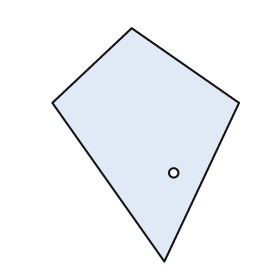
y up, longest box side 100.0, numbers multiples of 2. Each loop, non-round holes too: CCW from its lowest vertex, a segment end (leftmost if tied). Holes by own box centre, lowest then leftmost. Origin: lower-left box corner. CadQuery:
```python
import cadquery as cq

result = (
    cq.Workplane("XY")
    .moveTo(48.0, 0.0)
    .lineTo(80.0, 68.0)
    .lineTo(34.0, 100.0)
    .lineTo(0.0, 68.0)
    .close()
    .moveTo(52.0, 38.0)
    .circle(2.0)
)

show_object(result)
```